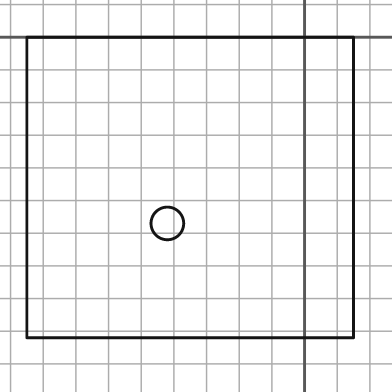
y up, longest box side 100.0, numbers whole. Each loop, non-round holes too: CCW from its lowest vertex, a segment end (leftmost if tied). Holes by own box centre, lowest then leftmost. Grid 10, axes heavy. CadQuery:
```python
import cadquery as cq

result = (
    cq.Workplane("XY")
    .moveTo(-85.0, -92.0)
    .lineTo(15.0, -92.0)
    .lineTo(15.0, 0.0)
    .lineTo(-85.0, 0.0)
    .close()
    .moveTo(-42.0, -57.0)
    .circle(5.0)
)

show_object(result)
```